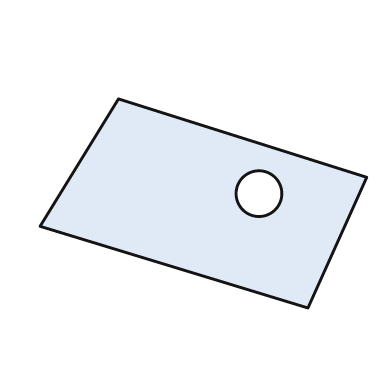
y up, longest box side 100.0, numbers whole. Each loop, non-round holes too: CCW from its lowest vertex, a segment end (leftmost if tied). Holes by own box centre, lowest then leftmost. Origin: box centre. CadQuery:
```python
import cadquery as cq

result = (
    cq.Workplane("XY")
    .moveTo(32.0, -32.0)
    .lineTo(50.0, 8.0)
    .lineTo(-26.0, 32.0)
    .lineTo(-50.0, -7.0)
    .close()
    .moveTo(17.0, 3.0)
    .circle(7.0)
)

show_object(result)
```